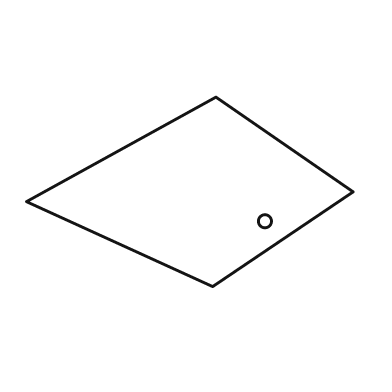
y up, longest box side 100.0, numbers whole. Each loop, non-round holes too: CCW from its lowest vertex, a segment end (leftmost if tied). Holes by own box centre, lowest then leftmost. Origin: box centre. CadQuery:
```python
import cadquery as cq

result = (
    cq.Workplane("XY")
    .moveTo(7.0, -29.0)
    .lineTo(50.0, 0.0)
    .lineTo(8.0, 29.0)
    .lineTo(-50.0, -3.0)
    .close()
    .moveTo(23.0, -9.0)
    .circle(2.0)
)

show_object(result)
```